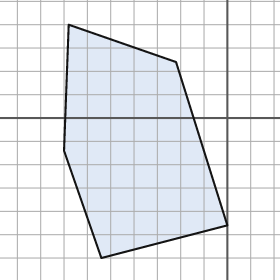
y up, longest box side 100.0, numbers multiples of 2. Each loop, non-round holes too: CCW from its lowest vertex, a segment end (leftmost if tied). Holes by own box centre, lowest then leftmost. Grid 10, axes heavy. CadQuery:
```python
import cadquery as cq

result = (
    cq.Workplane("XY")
    .moveTo(-54.0, -60.0)
    .lineTo(0.0, -46.0)
    .lineTo(-22.0, 24.0)
    .lineTo(-68.0, 40.0)
    .lineTo(-70.0, -14.0)
    .close()
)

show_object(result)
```